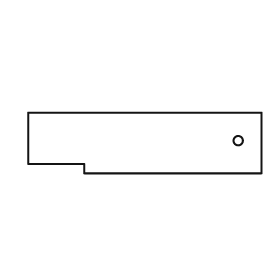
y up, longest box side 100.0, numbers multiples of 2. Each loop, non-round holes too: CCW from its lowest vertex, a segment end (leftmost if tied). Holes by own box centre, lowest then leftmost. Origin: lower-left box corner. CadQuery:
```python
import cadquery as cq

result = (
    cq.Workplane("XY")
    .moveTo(24.0, 0.0)
    .lineTo(100.0, 0.0)
    .lineTo(100.0, 26.0)
    .lineTo(0.0, 26.0)
    .lineTo(0.0, 4.0)
    .lineTo(24.0, 4.0)
    .close()
    .moveTo(90.0, 14.0)
    .circle(2.0)
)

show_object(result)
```